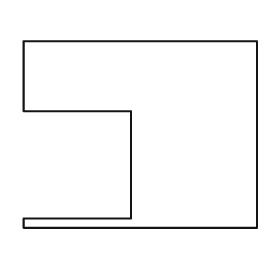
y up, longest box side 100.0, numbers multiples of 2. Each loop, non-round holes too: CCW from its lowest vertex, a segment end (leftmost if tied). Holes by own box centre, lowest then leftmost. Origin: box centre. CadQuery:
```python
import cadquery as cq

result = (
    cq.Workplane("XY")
    .moveTo(-50.0, -40.0)
    .lineTo(50.0, -40.0)
    .lineTo(50.0, 40.0)
    .lineTo(-50.0, 40.0)
    .lineTo(-50.0, 10.0)
    .lineTo(-4.0, 10.0)
    .lineTo(-4.0, -36.0)
    .lineTo(-50.0, -36.0)
    .close()
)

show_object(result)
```